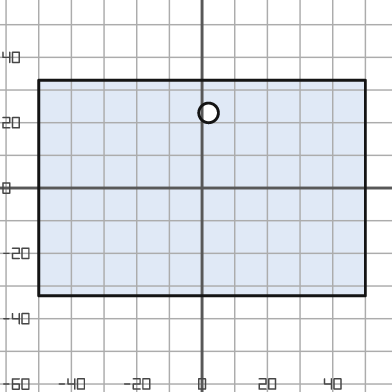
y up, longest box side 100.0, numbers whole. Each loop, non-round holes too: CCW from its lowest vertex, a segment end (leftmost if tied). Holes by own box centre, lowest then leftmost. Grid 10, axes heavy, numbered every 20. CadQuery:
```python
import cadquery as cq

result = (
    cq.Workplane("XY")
    .moveTo(-50.0, -33.0)
    .lineTo(50.0, -33.0)
    .lineTo(50.0, 33.0)
    .lineTo(-50.0, 33.0)
    .close()
    .moveTo(2.0, 23.0)
    .circle(3.0)
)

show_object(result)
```